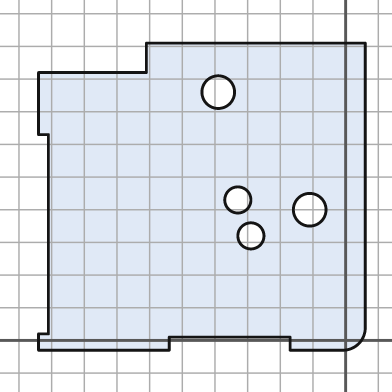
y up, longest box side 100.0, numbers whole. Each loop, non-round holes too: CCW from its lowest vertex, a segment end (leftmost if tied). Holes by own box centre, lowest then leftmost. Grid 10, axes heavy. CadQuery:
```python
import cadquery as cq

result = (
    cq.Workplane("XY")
    .moveTo(-94.0, -3.0)
    .lineTo(-54.0, -3.0)
    .lineTo(-54.0, 1.0)
    .lineTo(-17.0, 1.0)
    .lineTo(-17.0, -3.0)
    .lineTo(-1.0, -3.0)
    .threePointArc((4.0, -1.0), (6.0, 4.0))
    .lineTo(6.0, 91.0)
    .lineTo(-61.0, 91.0)
    .lineTo(-61.0, 82.0)
    .lineTo(-94.0, 82.0)
    .lineTo(-94.0, 63.0)
    .lineTo(-91.0, 63.0)
    .lineTo(-91.0, 2.0)
    .lineTo(-94.0, 2.0)
    .close()
    .moveTo(-29.0, 32.0)
    .circle(4.0)
    .moveTo(-11.0, 40.0)
    .circle(5.0)
    .moveTo(-33.0, 43.0)
    .circle(4.0)
    .moveTo(-39.0, 76.0)
    .circle(5.0)
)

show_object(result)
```